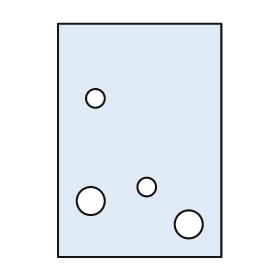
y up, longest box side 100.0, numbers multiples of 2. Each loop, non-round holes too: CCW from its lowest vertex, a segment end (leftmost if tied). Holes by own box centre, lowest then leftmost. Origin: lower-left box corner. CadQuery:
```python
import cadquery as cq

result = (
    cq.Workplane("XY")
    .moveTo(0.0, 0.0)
    .lineTo(70.0, 0.0)
    .lineTo(70.0, 100.0)
    .lineTo(0.0, 100.0)
    .close()
    .moveTo(56.0, 14.0)
    .circle(6.0)
    .moveTo(14.0, 24.0)
    .circle(6.0)
    .moveTo(38.0, 30.0)
    .circle(4.0)
    .moveTo(16.0, 68.0)
    .circle(4.0)
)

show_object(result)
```